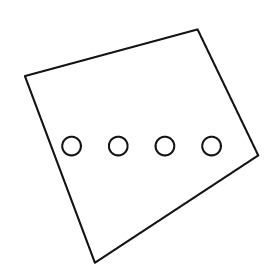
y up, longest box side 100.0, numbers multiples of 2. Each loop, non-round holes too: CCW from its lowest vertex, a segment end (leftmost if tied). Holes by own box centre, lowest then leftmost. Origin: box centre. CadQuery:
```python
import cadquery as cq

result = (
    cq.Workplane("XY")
    .moveTo(-20.0, -50.0)
    .lineTo(50.0, -4.0)
    .lineTo(24.0, 50.0)
    .lineTo(-50.0, 30.0)
    .close()
    .moveTo(-30.0, 0.0)
    .circle(4.0)
    .moveTo(-10.0, 0.0)
    .circle(4.0)
    .moveTo(10.0, 0.0)
    .circle(4.0)
    .moveTo(30.0, 0.0)
    .circle(4.0)
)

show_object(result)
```